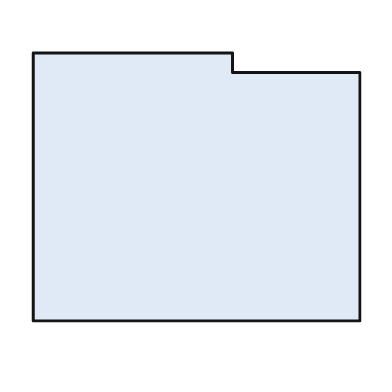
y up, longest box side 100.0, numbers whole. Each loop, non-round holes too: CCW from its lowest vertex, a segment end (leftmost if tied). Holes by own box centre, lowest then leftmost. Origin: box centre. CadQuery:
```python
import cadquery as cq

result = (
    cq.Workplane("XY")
    .moveTo(-50.0, -41.0)
    .lineTo(50.0, -41.0)
    .lineTo(50.0, 35.0)
    .lineTo(11.0, 35.0)
    .lineTo(11.0, 41.0)
    .lineTo(-50.0, 41.0)
    .close()
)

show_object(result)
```